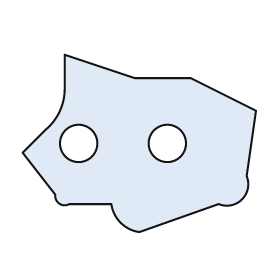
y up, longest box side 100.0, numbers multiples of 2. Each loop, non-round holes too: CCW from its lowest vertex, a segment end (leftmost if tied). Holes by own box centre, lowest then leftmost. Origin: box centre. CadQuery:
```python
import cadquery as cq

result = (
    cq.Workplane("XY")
    .moveTo(0.0, -38.0)
    .lineTo(34.0, -26.0)
    .threePointArc((44.0, -24.0), (46.0, -14.0))
    .lineTo(50.0, 14.0)
    .lineTo(22.0, 28.0)
    .lineTo(-2.0, 28.0)
    .lineTo(-32.0, 38.0)
    .lineTo(-32.0, 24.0)
    .threePointArc((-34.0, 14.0), (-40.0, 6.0))
    .lineTo(-50.0, -4.0)
    .lineTo(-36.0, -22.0)
    .threePointArc((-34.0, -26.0), (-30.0, -26.0))
    .lineTo(-12.0, -26.0)
    .threePointArc((-8.0, -34.0), (0.0, -38.0))
    .close()
    .moveTo(-26.0, 0.0)
    .circle(8.0)
    .moveTo(12.0, 0.0)
    .circle(8.0)
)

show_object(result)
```